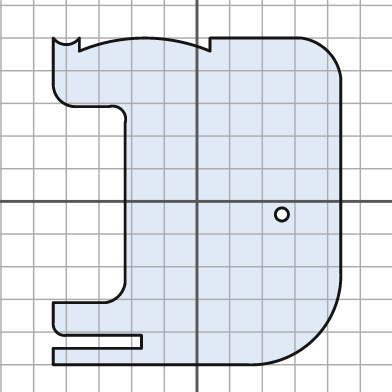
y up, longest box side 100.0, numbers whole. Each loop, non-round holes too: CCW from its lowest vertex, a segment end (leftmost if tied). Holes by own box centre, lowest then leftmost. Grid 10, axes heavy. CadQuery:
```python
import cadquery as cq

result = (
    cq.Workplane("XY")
    .moveTo(-44.0, -50.0)
    .lineTo(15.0, -50.0)
    .threePointArc((36.0, -42.0), (44.0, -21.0))
    .lineTo(44.0, 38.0)
    .threePointArc((40.0, 46.0), (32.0, 50.0))
    .lineTo(4.0, 50.0)
    .lineTo(4.0, 46.0)
    .threePointArc((-16.0, 50.0), (-36.0, 46.0))
    .lineTo(-36.0, 50.0)
    .threePointArc((-40.0, 48.0), (-44.0, 50.0))
    .lineTo(-44.0, 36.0)
    .threePointArc((-42.0, 31.0), (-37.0, 29.0))
    .lineTo(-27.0, 29.0)
    .threePointArc((-23.0, 28.0), (-22.0, 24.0))
    .lineTo(-22.0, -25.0)
    .threePointArc((-24.0, -29.0), (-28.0, -31.0))
    .lineTo(-44.0, -31.0)
    .lineTo(-44.0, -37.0)
    .threePointArc((-43.0, -40.0), (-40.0, -41.0))
    .lineTo(-17.0, -41.0)
    .lineTo(-17.0, -45.0)
    .lineTo(-44.0, -45.0)
    .close()
    .moveTo(26.0, -4.0)
    .circle(2.0)
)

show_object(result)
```